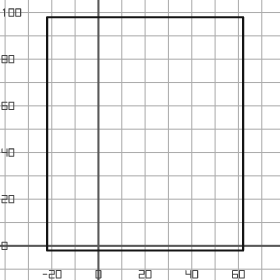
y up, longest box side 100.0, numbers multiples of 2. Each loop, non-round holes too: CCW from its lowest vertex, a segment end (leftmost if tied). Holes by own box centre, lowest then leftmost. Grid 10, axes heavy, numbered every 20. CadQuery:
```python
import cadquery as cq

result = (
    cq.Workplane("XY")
    .moveTo(-22.0, -2.0)
    .lineTo(62.0, -2.0)
    .lineTo(62.0, 98.0)
    .lineTo(-22.0, 98.0)
    .close()
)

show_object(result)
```